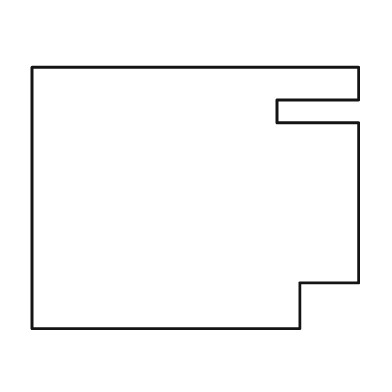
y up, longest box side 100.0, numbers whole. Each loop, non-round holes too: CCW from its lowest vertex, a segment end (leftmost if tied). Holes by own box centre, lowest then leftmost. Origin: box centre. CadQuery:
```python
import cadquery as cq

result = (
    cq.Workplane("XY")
    .moveTo(-50.0, -40.0)
    .lineTo(32.0, -40.0)
    .lineTo(32.0, -26.0)
    .lineTo(50.0, -26.0)
    .lineTo(50.0, 23.0)
    .lineTo(25.0, 23.0)
    .lineTo(25.0, 30.0)
    .lineTo(50.0, 30.0)
    .lineTo(50.0, 40.0)
    .lineTo(-50.0, 40.0)
    .close()
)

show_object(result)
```